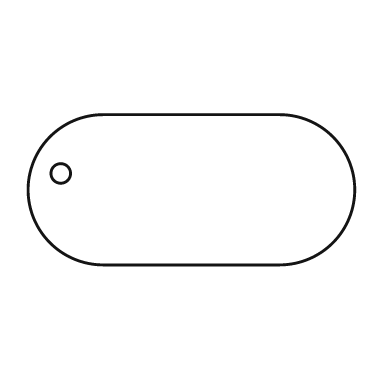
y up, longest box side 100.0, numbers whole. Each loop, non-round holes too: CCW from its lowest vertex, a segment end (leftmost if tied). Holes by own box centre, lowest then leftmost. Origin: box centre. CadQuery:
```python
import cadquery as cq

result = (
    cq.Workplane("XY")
    .moveTo(-27.0, -23.0)
    .lineTo(27.0, -23.0)
    .threePointArc((50.0, 0.0), (27.0, 23.0))
    .lineTo(-27.0, 23.0)
    .threePointArc((-50.0, 0.0), (-27.0, -23.0))
    .close()
    .moveTo(-40.0, 5.0)
    .circle(3.0)
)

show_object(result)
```